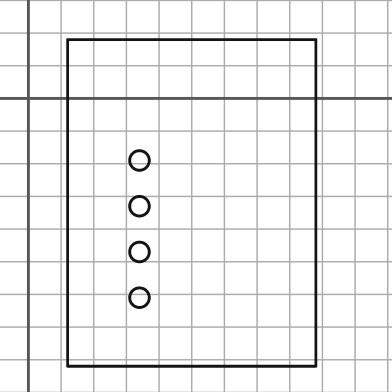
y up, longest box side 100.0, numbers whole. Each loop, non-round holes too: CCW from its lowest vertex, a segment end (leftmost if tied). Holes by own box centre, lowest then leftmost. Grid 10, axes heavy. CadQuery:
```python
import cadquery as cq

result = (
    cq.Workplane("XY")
    .moveTo(12.0, -82.0)
    .lineTo(88.0, -82.0)
    .lineTo(88.0, 18.0)
    .lineTo(12.0, 18.0)
    .close()
    .moveTo(34.0, -61.0)
    .circle(3.0)
    .moveTo(34.0, -47.0)
    .circle(3.0)
    .moveTo(34.0, -33.0)
    .circle(3.0)
    .moveTo(34.0, -19.0)
    .circle(3.0)
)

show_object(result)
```